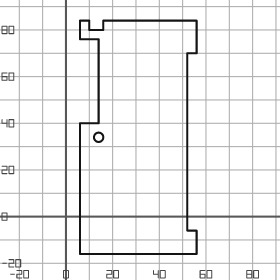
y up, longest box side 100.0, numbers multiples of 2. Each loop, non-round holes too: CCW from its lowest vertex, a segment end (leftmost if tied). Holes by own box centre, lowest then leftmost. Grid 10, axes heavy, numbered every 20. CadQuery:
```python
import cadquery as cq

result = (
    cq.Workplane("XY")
    .moveTo(6.0, -16.0)
    .lineTo(56.0, -16.0)
    .lineTo(56.0, -6.0)
    .lineTo(52.0, -6.0)
    .lineTo(52.0, 70.0)
    .lineTo(56.0, 70.0)
    .lineTo(56.0, 84.0)
    .lineTo(16.0, 84.0)
    .lineTo(16.0, 80.0)
    .lineTo(10.0, 80.0)
    .lineTo(10.0, 84.0)
    .lineTo(6.0, 84.0)
    .lineTo(6.0, 76.0)
    .lineTo(14.0, 76.0)
    .lineTo(14.0, 40.0)
    .lineTo(6.0, 40.0)
    .close()
    .moveTo(14.0, 34.0)
    .circle(2.0)
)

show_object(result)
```